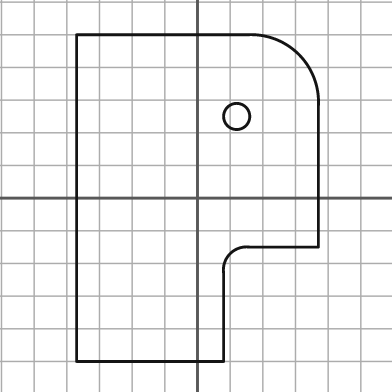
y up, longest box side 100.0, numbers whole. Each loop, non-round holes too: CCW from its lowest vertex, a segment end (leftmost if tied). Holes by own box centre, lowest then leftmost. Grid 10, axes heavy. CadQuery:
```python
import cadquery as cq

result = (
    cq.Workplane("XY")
    .moveTo(-37.0, -50.0)
    .lineTo(8.0, -50.0)
    .lineTo(8.0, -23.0)
    .threePointArc((10.0, -17.0), (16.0, -15.0))
    .lineTo(37.0, -15.0)
    .lineTo(37.0, 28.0)
    .threePointArc((31.0, 44.0), (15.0, 50.0))
    .lineTo(-37.0, 50.0)
    .close()
    .moveTo(12.0, 25.0)
    .circle(4.0)
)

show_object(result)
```